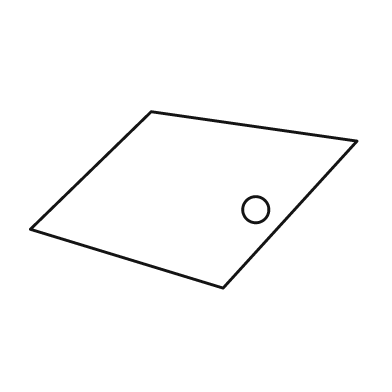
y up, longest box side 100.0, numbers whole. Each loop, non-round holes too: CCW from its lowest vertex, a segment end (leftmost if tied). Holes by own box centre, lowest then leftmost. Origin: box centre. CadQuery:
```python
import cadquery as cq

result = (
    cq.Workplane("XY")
    .moveTo(9.0, -27.0)
    .lineTo(50.0, 18.0)
    .lineTo(-13.0, 27.0)
    .lineTo(-50.0, -9.0)
    .close()
    .moveTo(19.0, -3.0)
    .circle(4.0)
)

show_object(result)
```